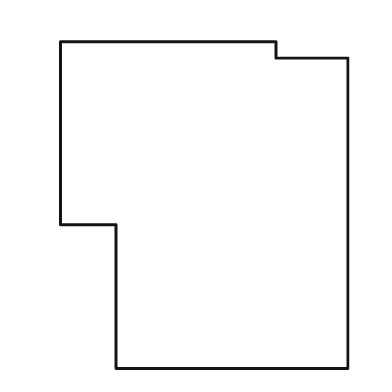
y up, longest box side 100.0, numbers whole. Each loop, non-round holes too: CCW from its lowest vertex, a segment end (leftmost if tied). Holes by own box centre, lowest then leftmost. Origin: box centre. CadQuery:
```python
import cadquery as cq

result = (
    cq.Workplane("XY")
    .moveTo(-27.0, -50.0)
    .lineTo(44.0, -50.0)
    .lineTo(44.0, 45.0)
    .lineTo(22.0, 45.0)
    .lineTo(22.0, 50.0)
    .lineTo(-44.0, 50.0)
    .lineTo(-44.0, -6.0)
    .lineTo(-27.0, -6.0)
    .close()
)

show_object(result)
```